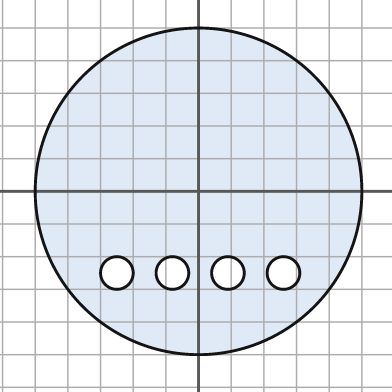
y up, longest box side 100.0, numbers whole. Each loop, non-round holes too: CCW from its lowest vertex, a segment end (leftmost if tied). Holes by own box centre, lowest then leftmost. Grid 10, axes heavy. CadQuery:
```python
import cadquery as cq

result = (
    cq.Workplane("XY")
    .moveTo(0.0, 0.0)
    .circle(50.0)
    .moveTo(-25.0, -25.0)
    .circle(5.0)
    .moveTo(-8.0, -25.0)
    .circle(5.0)
    .moveTo(9.0, -25.0)
    .circle(5.0)
    .moveTo(26.0, -25.0)
    .circle(5.0)
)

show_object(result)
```